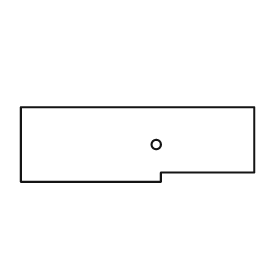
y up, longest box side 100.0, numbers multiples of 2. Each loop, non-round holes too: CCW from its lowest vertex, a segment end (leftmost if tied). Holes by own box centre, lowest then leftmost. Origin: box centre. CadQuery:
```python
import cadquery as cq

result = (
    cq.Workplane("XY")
    .moveTo(-50.0, -16.0)
    .lineTo(10.0, -16.0)
    .lineTo(10.0, -12.0)
    .lineTo(50.0, -12.0)
    .lineTo(50.0, 16.0)
    .lineTo(-50.0, 16.0)
    .close()
    .moveTo(8.0, 0.0)
    .circle(2.0)
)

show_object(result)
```